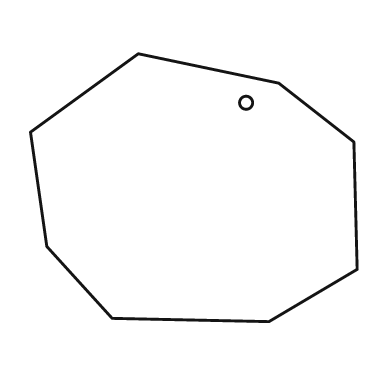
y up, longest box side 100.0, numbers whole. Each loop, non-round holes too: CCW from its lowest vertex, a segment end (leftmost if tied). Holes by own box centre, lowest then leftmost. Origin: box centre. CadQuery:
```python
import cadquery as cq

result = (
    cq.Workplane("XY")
    .moveTo(23.0, -41.0)
    .lineTo(50.0, -25.0)
    .lineTo(49.0, 14.0)
    .lineTo(26.0, 32.0)
    .lineTo(-17.0, 41.0)
    .lineTo(-50.0, 17.0)
    .lineTo(-45.0, -18.0)
    .lineTo(-25.0, -40.0)
    .close()
    .moveTo(16.0, 26.0)
    .circle(2.0)
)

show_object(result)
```